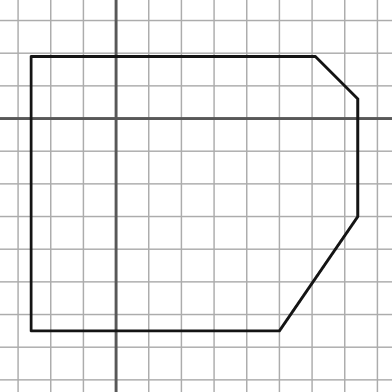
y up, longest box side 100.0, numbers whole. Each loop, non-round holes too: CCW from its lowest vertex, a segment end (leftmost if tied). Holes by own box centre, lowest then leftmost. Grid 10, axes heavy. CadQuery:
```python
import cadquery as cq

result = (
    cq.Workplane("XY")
    .moveTo(-26.0, -65.0)
    .lineTo(50.0, -65.0)
    .lineTo(74.0, -30.0)
    .lineTo(74.0, 6.0)
    .lineTo(61.0, 19.0)
    .lineTo(-26.0, 19.0)
    .close()
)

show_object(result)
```